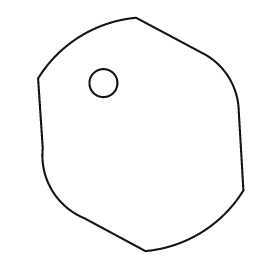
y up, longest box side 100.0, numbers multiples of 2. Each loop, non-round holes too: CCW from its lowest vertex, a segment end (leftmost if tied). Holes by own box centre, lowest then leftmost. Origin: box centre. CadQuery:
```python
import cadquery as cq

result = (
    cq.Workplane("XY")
    .moveTo(2.0, -50.0)
    .threePointArc((26.0, -42.0), (44.0, -24.0))
    .lineTo(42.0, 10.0)
    .threePointArc((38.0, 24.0), (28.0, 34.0))
    .lineTo(-2.0, 50.0)
    .threePointArc((-26.0, 42.0), (-44.0, 24.0))
    .lineTo(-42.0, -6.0)
    .threePointArc((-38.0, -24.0), (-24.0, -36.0))
    .close()
    .moveTo(-16.0, 22.0)
    .circle(6.0)
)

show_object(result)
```